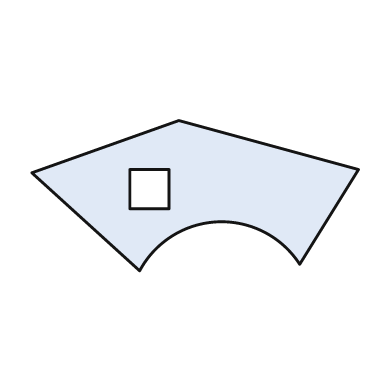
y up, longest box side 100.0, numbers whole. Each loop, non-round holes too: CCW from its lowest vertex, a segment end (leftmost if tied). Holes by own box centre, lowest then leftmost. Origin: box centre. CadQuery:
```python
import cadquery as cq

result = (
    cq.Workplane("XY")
    .moveTo(-17.0, -23.0)
    .threePointArc((7.0, -8.0), (32.0, -21.0))
    .lineTo(50.0, 8.0)
    .lineTo(-5.0, 23.0)
    .lineTo(-50.0, 7.0)
    .close()
    .moveTo(-20.0, -4.0)
    .lineTo(-8.0, -4.0)
    .lineTo(-8.0, 8.0)
    .lineTo(-20.0, 8.0)
    .close()
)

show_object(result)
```